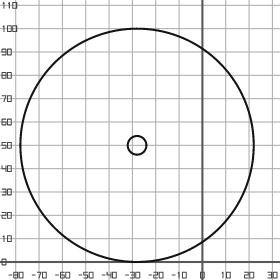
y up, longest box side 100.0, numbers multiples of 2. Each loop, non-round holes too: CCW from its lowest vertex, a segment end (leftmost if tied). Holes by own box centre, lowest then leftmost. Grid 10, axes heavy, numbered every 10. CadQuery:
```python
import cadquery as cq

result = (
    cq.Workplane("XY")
    .moveTo(-28.0, 50.0)
    .circle(50.0)
    .moveTo(-28.0, 50.0)
    .circle(4.0)
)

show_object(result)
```